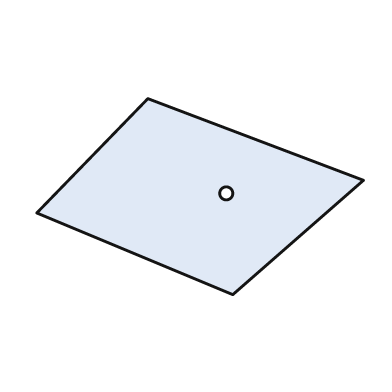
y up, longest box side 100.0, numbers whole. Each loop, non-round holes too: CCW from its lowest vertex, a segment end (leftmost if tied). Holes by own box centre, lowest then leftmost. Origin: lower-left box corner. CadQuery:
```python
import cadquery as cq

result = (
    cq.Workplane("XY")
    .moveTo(60.0, 0.0)
    .lineTo(100.0, 35.0)
    .lineTo(34.0, 60.0)
    .lineTo(0.0, 25.0)
    .close()
    .moveTo(58.0, 31.0)
    .circle(2.0)
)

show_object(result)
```